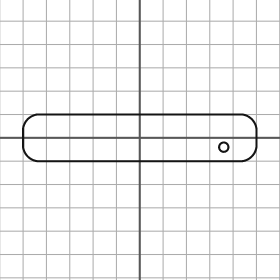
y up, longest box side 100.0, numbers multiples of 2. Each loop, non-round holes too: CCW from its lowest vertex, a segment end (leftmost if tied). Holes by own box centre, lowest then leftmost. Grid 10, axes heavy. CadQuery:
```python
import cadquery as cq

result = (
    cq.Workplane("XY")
    .moveTo(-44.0, -10.0)
    .lineTo(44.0, -10.0)
    .threePointArc((48.0, -8.0), (50.0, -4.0))
    .lineTo(50.0, 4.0)
    .threePointArc((48.0, 8.0), (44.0, 10.0))
    .lineTo(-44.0, 10.0)
    .threePointArc((-48.0, 8.0), (-50.0, 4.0))
    .lineTo(-50.0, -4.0)
    .threePointArc((-48.0, -8.0), (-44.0, -10.0))
    .close()
    .moveTo(36.0, -4.0)
    .circle(2.0)
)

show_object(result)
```